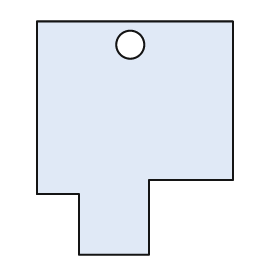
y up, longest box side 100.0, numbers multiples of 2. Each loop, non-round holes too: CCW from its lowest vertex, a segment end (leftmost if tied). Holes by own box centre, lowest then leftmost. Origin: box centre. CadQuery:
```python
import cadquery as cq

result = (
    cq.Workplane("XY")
    .moveTo(-24.0, -50.0)
    .lineTo(6.0, -50.0)
    .lineTo(6.0, -18.0)
    .lineTo(42.0, -18.0)
    .lineTo(42.0, 50.0)
    .lineTo(-42.0, 50.0)
    .lineTo(-42.0, -24.0)
    .lineTo(-24.0, -24.0)
    .close()
    .moveTo(-2.0, 40.0)
    .circle(6.0)
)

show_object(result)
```